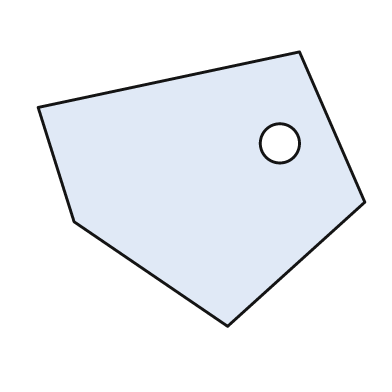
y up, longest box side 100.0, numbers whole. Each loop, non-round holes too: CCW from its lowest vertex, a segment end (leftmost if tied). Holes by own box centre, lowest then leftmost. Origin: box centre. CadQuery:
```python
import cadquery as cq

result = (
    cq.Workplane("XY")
    .moveTo(8.0, -42.0)
    .lineTo(50.0, -4.0)
    .lineTo(30.0, 42.0)
    .lineTo(-50.0, 25.0)
    .lineTo(-39.0, -10.0)
    .close()
    .moveTo(24.0, 14.0)
    .circle(6.0)
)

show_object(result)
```